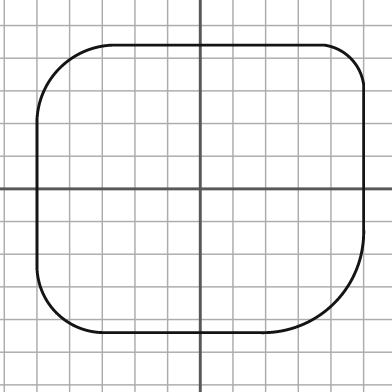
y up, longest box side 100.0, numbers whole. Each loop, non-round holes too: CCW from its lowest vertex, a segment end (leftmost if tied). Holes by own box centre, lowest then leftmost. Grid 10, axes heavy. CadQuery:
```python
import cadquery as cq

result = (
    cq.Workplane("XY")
    .moveTo(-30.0, -44.0)
    .lineTo(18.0, -44.0)
    .threePointArc((41.0, -35.0), (50.0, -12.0))
    .lineTo(50.0, 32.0)
    .threePointArc((46.0, 40.0), (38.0, 44.0))
    .lineTo(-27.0, 44.0)
    .threePointArc((-43.0, 37.0), (-50.0, 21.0))
    .lineTo(-50.0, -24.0)
    .threePointArc((-44.0, -38.0), (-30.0, -44.0))
    .close()
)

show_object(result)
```